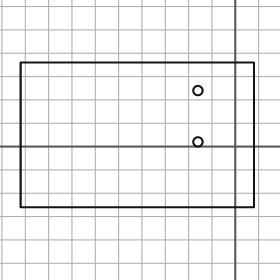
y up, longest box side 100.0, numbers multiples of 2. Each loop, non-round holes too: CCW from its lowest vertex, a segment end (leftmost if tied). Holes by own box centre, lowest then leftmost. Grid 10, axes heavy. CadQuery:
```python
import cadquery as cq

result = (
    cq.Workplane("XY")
    .moveTo(-92.0, -26.0)
    .lineTo(8.0, -26.0)
    .lineTo(8.0, 36.0)
    .lineTo(-92.0, 36.0)
    .close()
    .moveTo(-16.0, 2.0)
    .circle(2.0)
    .moveTo(-16.0, 24.0)
    .circle(2.0)
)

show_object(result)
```